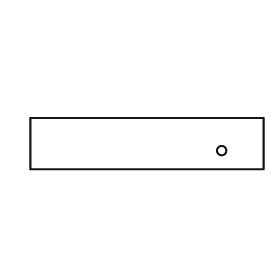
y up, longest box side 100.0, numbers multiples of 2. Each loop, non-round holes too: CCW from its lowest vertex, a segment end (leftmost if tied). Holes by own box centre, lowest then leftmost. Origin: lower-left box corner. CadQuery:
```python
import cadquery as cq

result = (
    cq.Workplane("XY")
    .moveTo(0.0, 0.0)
    .lineTo(100.0, 0.0)
    .lineTo(100.0, 22.0)
    .lineTo(0.0, 22.0)
    .close()
    .moveTo(82.0, 8.0)
    .circle(2.0)
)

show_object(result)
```